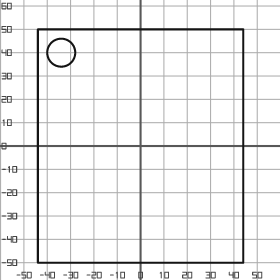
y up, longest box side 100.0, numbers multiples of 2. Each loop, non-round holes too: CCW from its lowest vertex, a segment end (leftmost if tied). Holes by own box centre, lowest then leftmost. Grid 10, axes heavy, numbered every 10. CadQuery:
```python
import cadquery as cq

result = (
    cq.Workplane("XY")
    .moveTo(-44.0, -50.0)
    .lineTo(44.0, -50.0)
    .lineTo(44.0, 50.0)
    .lineTo(-44.0, 50.0)
    .close()
    .moveTo(-34.0, 40.0)
    .circle(6.0)
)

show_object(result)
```